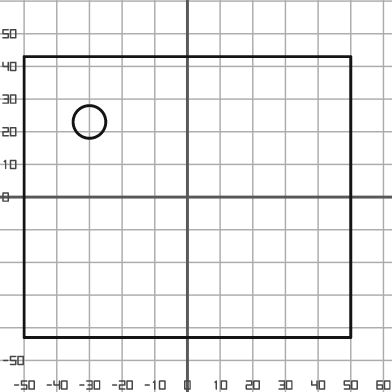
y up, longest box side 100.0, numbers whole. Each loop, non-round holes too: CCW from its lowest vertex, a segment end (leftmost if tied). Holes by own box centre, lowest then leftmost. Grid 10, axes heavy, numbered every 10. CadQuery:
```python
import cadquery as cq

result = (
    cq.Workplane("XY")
    .moveTo(-50.0, -43.0)
    .lineTo(50.0, -43.0)
    .lineTo(50.0, 43.0)
    .lineTo(-50.0, 43.0)
    .close()
    .moveTo(-30.0, 23.0)
    .circle(5.0)
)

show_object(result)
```